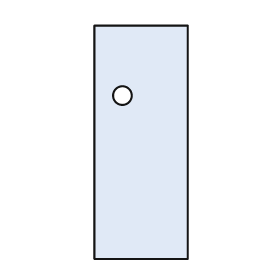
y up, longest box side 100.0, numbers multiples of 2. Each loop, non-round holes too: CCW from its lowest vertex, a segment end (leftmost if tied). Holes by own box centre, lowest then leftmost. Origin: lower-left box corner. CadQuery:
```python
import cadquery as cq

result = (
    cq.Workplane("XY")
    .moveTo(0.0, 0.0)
    .lineTo(40.0, 0.0)
    .lineTo(40.0, 100.0)
    .lineTo(0.0, 100.0)
    .close()
    .moveTo(12.0, 70.0)
    .circle(4.0)
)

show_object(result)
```